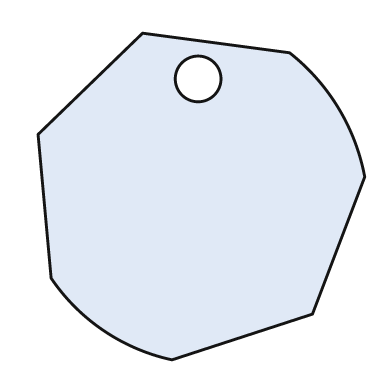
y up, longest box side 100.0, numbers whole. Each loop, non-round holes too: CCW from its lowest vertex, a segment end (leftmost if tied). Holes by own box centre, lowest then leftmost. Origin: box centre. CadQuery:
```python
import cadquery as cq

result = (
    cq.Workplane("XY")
    .moveTo(-9.0, -50.0)
    .lineTo(34.0, -36.0)
    .lineTo(50.0, 6.0)
    .threePointArc((42.0, 27.0), (27.0, 44.0))
    .lineTo(-18.0, 50.0)
    .lineTo(-50.0, 19.0)
    .lineTo(-46.0, -25.0)
    .threePointArc((-30.0, -41.0), (-9.0, -50.0))
    .close()
    .moveTo(-1.0, 36.0)
    .circle(7.0)
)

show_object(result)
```